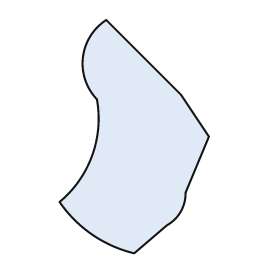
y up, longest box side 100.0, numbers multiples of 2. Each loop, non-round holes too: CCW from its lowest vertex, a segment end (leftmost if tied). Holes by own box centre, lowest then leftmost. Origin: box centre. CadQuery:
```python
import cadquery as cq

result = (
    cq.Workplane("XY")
    .moveTo(0.0, -50.0)
    .lineTo(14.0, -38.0)
    .threePointArc((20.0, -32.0), (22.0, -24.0))
    .lineTo(32.0, 0.0)
    .lineTo(20.0, 18.0)
    .lineTo(-12.0, 50.0)
    .threePointArc((-22.0, 34.0), (-16.0, 16.0))
    .threePointArc((-18.0, -8.0), (-32.0, -28.0))
    .threePointArc((-18.0, -42.0), (0.0, -50.0))
    .close()
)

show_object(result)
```